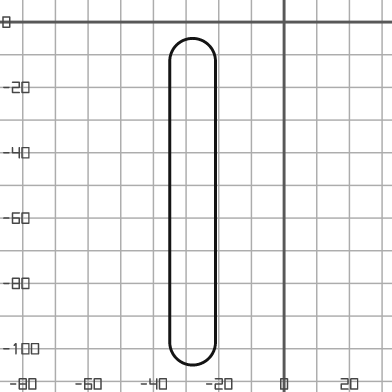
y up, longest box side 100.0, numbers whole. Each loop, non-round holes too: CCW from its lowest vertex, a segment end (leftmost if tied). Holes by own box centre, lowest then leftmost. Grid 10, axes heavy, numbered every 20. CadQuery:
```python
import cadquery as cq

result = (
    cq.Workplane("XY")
    .moveTo(-35.0, -98.0)
    .threePointArc((-28.0, -105.0), (-21.0, -98.0))
    .lineTo(-21.0, -12.0)
    .threePointArc((-28.0, -5.0), (-35.0, -12.0))
    .close()
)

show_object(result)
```